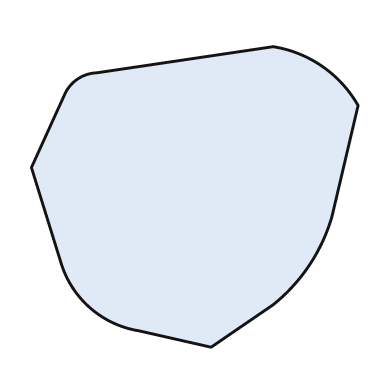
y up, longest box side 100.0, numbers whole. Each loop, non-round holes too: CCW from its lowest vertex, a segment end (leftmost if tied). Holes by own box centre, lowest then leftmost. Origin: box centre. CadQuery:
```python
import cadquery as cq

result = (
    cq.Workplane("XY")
    .moveTo(5.0, -46.0)
    .lineTo(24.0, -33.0)
    .threePointArc((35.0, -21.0), (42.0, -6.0))
    .lineTo(50.0, 28.0)
    .threePointArc((39.0, 40.0), (24.0, 46.0))
    .lineTo(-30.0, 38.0)
    .threePointArc((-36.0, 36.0), (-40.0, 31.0))
    .lineTo(-50.0, 9.0)
    .lineTo(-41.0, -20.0)
    .threePointArc((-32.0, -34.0), (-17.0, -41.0))
    .close()
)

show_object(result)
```